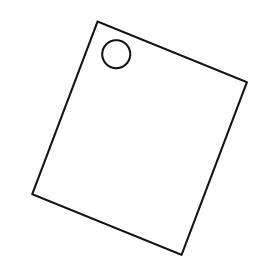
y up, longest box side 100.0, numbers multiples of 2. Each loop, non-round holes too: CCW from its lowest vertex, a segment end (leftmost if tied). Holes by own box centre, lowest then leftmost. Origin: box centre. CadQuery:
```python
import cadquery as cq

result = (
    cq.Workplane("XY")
    .moveTo(18.0, -50.0)
    .lineTo(46.0, 24.0)
    .lineTo(-18.0, 50.0)
    .lineTo(-46.0, -24.0)
    .close()
    .moveTo(-10.0, 36.0)
    .circle(6.0)
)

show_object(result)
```